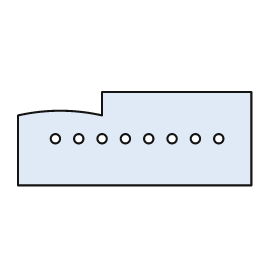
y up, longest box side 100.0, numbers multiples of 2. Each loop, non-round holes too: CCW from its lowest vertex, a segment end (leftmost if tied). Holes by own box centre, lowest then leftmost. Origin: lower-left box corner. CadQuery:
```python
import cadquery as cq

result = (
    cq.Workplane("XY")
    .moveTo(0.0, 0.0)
    .lineTo(100.0, 0.0)
    .lineTo(100.0, 40.0)
    .lineTo(36.0, 40.0)
    .lineTo(36.0, 30.0)
    .threePointArc((18.0, 32.0), (0.0, 30.0))
    .close()
    .moveTo(16.0, 20.0)
    .circle(2.0)
    .moveTo(26.0, 20.0)
    .circle(2.0)
    .moveTo(36.0, 20.0)
    .circle(2.0)
    .moveTo(46.0, 20.0)
    .circle(2.0)
    .moveTo(56.0, 20.0)
    .circle(2.0)
    .moveTo(66.0, 20.0)
    .circle(2.0)
    .moveTo(76.0, 20.0)
    .circle(2.0)
    .moveTo(86.0, 20.0)
    .circle(2.0)
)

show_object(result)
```